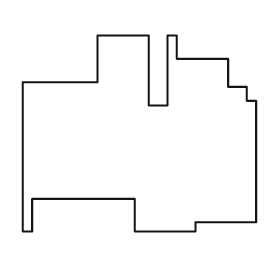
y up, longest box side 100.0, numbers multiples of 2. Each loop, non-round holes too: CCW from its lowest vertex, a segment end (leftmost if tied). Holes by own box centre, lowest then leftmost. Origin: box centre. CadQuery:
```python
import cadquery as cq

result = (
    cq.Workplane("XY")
    .moveTo(-50.0, -42.0)
    .lineTo(-46.0, -42.0)
    .lineTo(-46.0, -28.0)
    .lineTo(-2.0, -28.0)
    .lineTo(-2.0, -42.0)
    .lineTo(24.0, -42.0)
    .lineTo(24.0, -38.0)
    .lineTo(50.0, -38.0)
    .lineTo(50.0, 14.0)
    .lineTo(46.0, 14.0)
    .lineTo(46.0, 20.0)
    .lineTo(38.0, 20.0)
    .lineTo(38.0, 32.0)
    .lineTo(16.0, 32.0)
    .lineTo(16.0, 42.0)
    .lineTo(12.0, 42.0)
    .lineTo(12.0, 12.0)
    .lineTo(4.0, 12.0)
    .lineTo(4.0, 42.0)
    .lineTo(-18.0, 42.0)
    .lineTo(-18.0, 22.0)
    .lineTo(-50.0, 22.0)
    .close()
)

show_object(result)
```